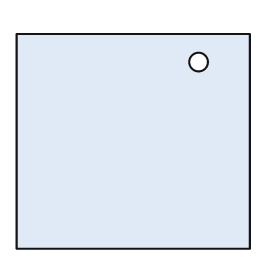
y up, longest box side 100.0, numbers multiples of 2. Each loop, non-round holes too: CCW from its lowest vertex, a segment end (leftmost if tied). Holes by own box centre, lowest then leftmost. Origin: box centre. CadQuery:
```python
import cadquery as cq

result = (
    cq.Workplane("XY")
    .moveTo(-50.0, -46.0)
    .lineTo(50.0, -46.0)
    .lineTo(50.0, 46.0)
    .lineTo(-50.0, 46.0)
    .close()
    .moveTo(28.0, 34.0)
    .circle(4.0)
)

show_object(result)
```